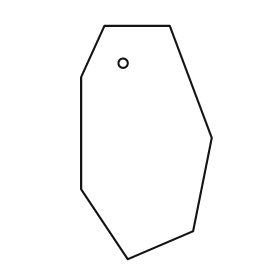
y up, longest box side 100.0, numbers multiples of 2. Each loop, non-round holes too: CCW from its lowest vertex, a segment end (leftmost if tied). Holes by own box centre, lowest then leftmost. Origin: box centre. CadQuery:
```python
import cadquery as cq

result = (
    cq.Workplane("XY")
    .moveTo(-8.0, -50.0)
    .lineTo(20.0, -38.0)
    .lineTo(28.0, 2.0)
    .lineTo(10.0, 50.0)
    .lineTo(-18.0, 50.0)
    .lineTo(-28.0, 28.0)
    .lineTo(-28.0, -20.0)
    .close()
    .moveTo(-10.0, 34.0)
    .circle(2.0)
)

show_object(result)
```